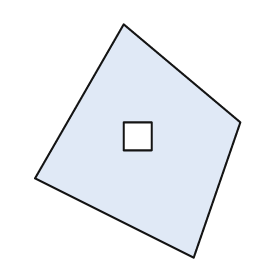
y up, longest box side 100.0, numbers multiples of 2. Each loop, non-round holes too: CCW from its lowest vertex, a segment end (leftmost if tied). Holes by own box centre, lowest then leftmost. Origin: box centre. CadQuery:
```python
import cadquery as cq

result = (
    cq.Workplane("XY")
    .moveTo(24.0, -50.0)
    .lineTo(44.0, 8.0)
    .lineTo(-6.0, 50.0)
    .lineTo(-44.0, -16.0)
    .close()
    .moveTo(-6.0, -4.0)
    .lineTo(6.0, -4.0)
    .lineTo(6.0, 8.0)
    .lineTo(-6.0, 8.0)
    .close()
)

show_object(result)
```